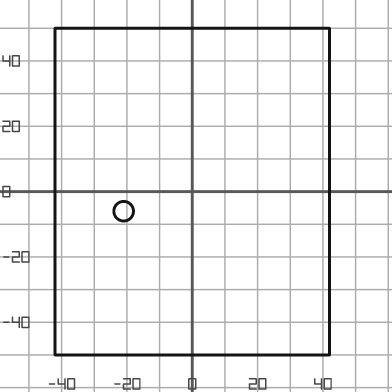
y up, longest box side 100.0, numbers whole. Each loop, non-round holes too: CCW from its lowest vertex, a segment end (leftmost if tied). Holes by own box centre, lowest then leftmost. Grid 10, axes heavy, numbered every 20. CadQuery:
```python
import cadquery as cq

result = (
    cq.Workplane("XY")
    .moveTo(-42.0, -50.0)
    .lineTo(42.0, -50.0)
    .lineTo(42.0, 50.0)
    .lineTo(-42.0, 50.0)
    .close()
    .moveTo(-21.0, -6.0)
    .circle(3.0)
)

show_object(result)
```